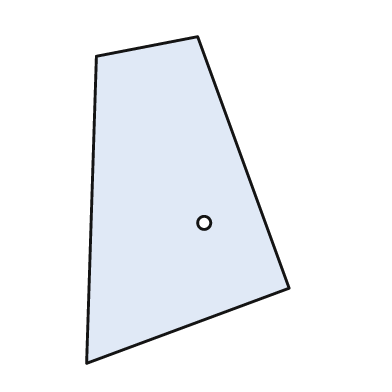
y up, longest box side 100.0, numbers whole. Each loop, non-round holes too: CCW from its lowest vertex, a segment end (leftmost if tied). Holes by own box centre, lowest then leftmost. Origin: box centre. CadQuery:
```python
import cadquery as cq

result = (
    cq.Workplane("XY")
    .moveTo(-31.0, -50.0)
    .lineTo(31.0, -27.0)
    .lineTo(3.0, 50.0)
    .lineTo(-28.0, 44.0)
    .close()
    .moveTo(5.0, -7.0)
    .circle(2.0)
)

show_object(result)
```